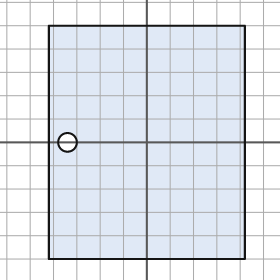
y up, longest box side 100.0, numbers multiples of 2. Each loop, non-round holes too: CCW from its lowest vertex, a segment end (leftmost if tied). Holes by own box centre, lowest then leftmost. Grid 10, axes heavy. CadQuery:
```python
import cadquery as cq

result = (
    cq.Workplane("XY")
    .moveTo(-42.0, -50.0)
    .lineTo(42.0, -50.0)
    .lineTo(42.0, 50.0)
    .lineTo(-42.0, 50.0)
    .close()
    .moveTo(-34.0, 0.0)
    .circle(4.0)
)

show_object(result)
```